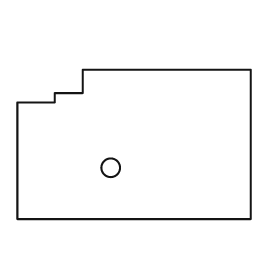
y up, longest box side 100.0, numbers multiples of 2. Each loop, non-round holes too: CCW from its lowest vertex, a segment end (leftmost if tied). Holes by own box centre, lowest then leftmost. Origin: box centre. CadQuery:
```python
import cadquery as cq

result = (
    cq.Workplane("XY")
    .moveTo(-50.0, -32.0)
    .lineTo(50.0, -32.0)
    .lineTo(50.0, 32.0)
    .lineTo(-22.0, 32.0)
    .lineTo(-22.0, 22.0)
    .lineTo(-34.0, 22.0)
    .lineTo(-34.0, 18.0)
    .lineTo(-50.0, 18.0)
    .close()
    .moveTo(-10.0, -10.0)
    .circle(4.0)
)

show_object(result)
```